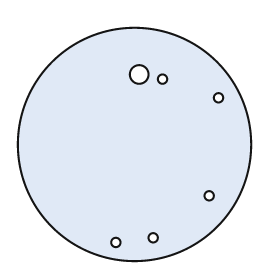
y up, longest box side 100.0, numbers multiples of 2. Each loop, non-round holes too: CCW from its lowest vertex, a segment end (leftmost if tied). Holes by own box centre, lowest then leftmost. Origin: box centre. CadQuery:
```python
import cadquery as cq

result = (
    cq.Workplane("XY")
    .moveTo(0.0, 0.0)
    .circle(50.0)
    .moveTo(-8.0, -42.0)
    .circle(2.0)
    .moveTo(8.0, -40.0)
    .circle(2.0)
    .moveTo(32.0, -22.0)
    .circle(2.0)
    .moveTo(36.0, 20.0)
    .circle(2.0)
    .moveTo(12.0, 28.0)
    .circle(2.0)
    .moveTo(2.0, 30.0)
    .circle(4.0)
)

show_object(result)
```